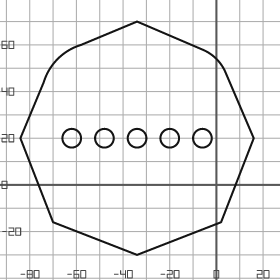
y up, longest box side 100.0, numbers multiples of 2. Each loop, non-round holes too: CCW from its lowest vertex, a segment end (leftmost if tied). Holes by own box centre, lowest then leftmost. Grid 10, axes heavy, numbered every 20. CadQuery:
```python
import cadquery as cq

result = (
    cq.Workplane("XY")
    .moveTo(-34.0, -30.0)
    .lineTo(2.0, -16.0)
    .lineTo(16.0, 20.0)
    .lineTo(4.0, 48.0)
    .threePointArc((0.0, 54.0), (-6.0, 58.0))
    .lineTo(-34.0, 70.0)
    .lineTo(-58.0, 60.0)
    .threePointArc((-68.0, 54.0), (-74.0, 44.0))
    .lineTo(-84.0, 20.0)
    .lineTo(-70.0, -16.0)
    .close()
    .moveTo(-62.0, 20.0)
    .circle(4.0)
    .moveTo(-48.0, 20.0)
    .circle(4.0)
    .moveTo(-34.0, 20.0)
    .circle(4.0)
    .moveTo(-20.0, 20.0)
    .circle(4.0)
    .moveTo(-6.0, 20.0)
    .circle(4.0)
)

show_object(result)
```